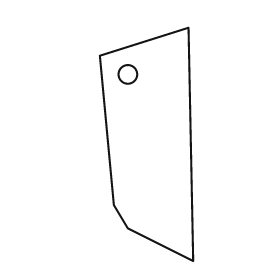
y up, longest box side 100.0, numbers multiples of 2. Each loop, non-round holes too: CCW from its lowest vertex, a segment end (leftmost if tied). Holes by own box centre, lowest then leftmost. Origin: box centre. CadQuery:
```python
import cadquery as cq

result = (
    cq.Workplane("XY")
    .moveTo(20.0, -50.0)
    .lineTo(18.0, 50.0)
    .lineTo(-20.0, 38.0)
    .lineTo(-14.0, -26.0)
    .lineTo(-8.0, -36.0)
    .close()
    .moveTo(-8.0, 30.0)
    .circle(4.0)
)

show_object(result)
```